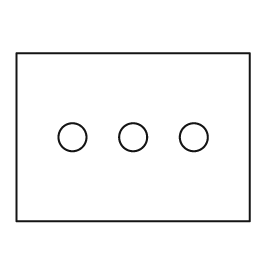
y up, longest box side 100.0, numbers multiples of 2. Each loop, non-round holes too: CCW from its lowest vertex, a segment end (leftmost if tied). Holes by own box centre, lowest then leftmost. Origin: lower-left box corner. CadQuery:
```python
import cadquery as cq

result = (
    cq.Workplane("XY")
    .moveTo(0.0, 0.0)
    .lineTo(100.0, 0.0)
    .lineTo(100.0, 72.0)
    .lineTo(0.0, 72.0)
    .close()
    .moveTo(24.0, 36.0)
    .circle(6.0)
    .moveTo(50.0, 36.0)
    .circle(6.0)
    .moveTo(76.0, 36.0)
    .circle(6.0)
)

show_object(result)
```